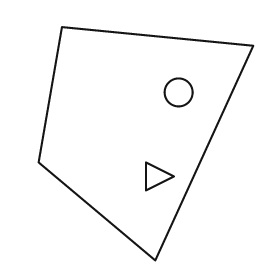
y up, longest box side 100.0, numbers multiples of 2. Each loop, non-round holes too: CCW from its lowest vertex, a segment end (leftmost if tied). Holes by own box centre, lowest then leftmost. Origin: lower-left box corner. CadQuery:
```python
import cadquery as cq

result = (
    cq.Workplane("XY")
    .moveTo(50.0, 0.0)
    .lineTo(92.0, 92.0)
    .lineTo(10.0, 100.0)
    .lineTo(0.0, 42.0)
    .close()
    .moveTo(46.0, 30.0)
    .lineTo(58.0, 36.0)
    .lineTo(46.0, 42.0)
    .close()
    .moveTo(60.0, 72.0)
    .circle(6.0)
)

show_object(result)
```